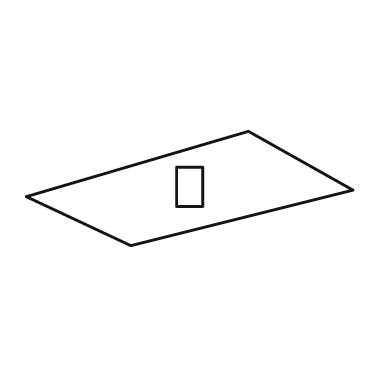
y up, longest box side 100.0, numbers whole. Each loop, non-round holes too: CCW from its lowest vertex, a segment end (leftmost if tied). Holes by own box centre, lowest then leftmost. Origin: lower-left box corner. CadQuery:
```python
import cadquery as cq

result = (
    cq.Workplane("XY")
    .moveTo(32.0, 0.0)
    .lineTo(100.0, 17.0)
    .lineTo(68.0, 35.0)
    .lineTo(0.0, 15.0)
    .close()
    .moveTo(46.0, 12.0)
    .lineTo(54.0, 12.0)
    .lineTo(54.0, 24.0)
    .lineTo(46.0, 24.0)
    .close()
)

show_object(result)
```